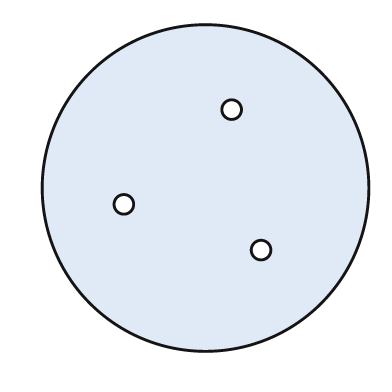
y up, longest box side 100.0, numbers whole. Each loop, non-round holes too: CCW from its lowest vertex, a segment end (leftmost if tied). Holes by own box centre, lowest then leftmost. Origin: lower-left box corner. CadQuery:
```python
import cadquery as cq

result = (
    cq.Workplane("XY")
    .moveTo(50.0, 50.0)
    .circle(50.0)
    .moveTo(67.0, 31.0)
    .circle(3.0)
    .moveTo(25.0, 45.0)
    .circle(3.0)
    .moveTo(58.0, 74.0)
    .circle(3.0)
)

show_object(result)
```